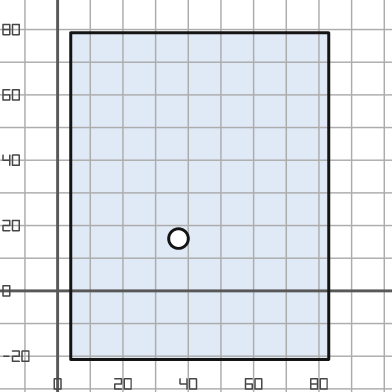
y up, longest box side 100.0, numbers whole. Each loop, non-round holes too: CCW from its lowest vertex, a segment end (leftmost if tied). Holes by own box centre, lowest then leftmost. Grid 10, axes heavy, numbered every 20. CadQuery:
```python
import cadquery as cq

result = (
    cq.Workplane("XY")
    .moveTo(4.0, -21.0)
    .lineTo(83.0, -21.0)
    .lineTo(83.0, 79.0)
    .lineTo(4.0, 79.0)
    .close()
    .moveTo(37.0, 16.0)
    .circle(3.0)
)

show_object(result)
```